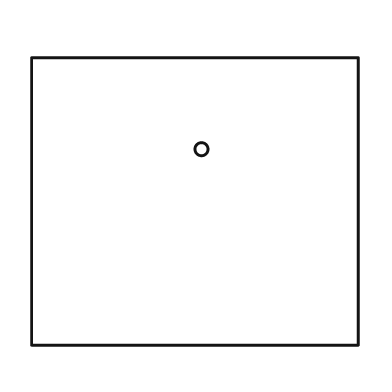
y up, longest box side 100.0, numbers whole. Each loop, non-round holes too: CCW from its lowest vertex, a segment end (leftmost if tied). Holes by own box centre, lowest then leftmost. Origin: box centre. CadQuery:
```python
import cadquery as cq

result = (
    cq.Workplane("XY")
    .moveTo(-50.0, -44.0)
    .lineTo(50.0, -44.0)
    .lineTo(50.0, 44.0)
    .lineTo(-50.0, 44.0)
    .close()
    .moveTo(2.0, 16.0)
    .circle(2.0)
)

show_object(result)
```